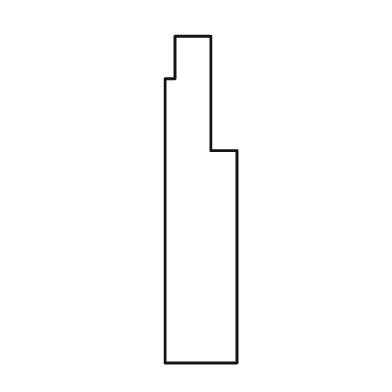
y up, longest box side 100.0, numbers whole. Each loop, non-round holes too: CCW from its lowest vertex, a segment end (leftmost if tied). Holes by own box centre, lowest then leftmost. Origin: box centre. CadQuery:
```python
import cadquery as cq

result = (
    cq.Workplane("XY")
    .moveTo(-11.0, -50.0)
    .lineTo(11.0, -50.0)
    .lineTo(11.0, 15.0)
    .lineTo(3.0, 15.0)
    .lineTo(3.0, 50.0)
    .lineTo(-8.0, 50.0)
    .lineTo(-8.0, 37.0)
    .lineTo(-11.0, 37.0)
    .close()
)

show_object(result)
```